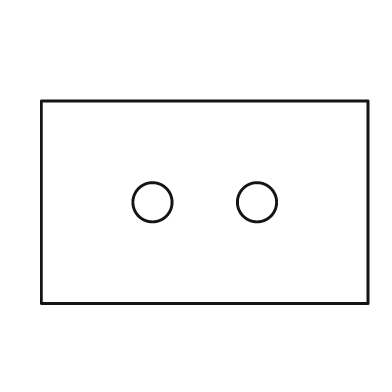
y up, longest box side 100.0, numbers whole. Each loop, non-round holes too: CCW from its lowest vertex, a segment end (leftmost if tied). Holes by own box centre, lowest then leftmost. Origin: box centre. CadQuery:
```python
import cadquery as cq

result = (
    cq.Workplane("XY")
    .moveTo(-50.0, -31.0)
    .lineTo(50.0, -31.0)
    .lineTo(50.0, 31.0)
    .lineTo(-50.0, 31.0)
    .close()
    .moveTo(-16.0, 0.0)
    .circle(6.0)
    .moveTo(16.0, 0.0)
    .circle(6.0)
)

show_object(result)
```